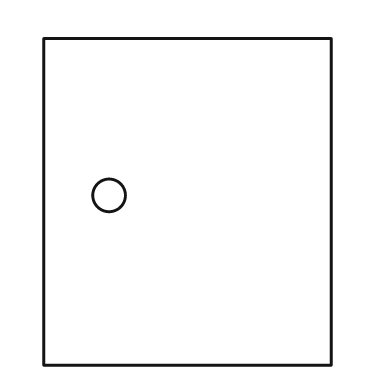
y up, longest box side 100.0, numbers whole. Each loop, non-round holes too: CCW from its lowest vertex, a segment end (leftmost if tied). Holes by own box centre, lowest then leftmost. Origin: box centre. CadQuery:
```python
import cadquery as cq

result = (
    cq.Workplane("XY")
    .moveTo(-44.0, -50.0)
    .lineTo(44.0, -50.0)
    .lineTo(44.0, 50.0)
    .lineTo(-44.0, 50.0)
    .close()
    .moveTo(-24.0, 2.0)
    .circle(5.0)
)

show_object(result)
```